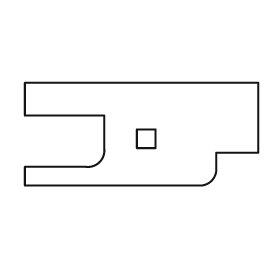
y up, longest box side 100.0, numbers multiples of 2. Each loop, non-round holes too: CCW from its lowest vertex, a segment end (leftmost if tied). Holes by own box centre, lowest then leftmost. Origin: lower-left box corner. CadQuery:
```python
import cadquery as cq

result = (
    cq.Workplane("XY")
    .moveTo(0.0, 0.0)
    .lineTo(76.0, 0.0)
    .threePointArc((80.0, 2.0), (82.0, 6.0))
    .lineTo(82.0, 14.0)
    .lineTo(100.0, 14.0)
    .lineTo(100.0, 44.0)
    .lineTo(0.0, 44.0)
    .lineTo(0.0, 30.0)
    .lineTo(34.0, 30.0)
    .lineTo(34.0, 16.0)
    .threePointArc((32.0, 10.0), (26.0, 8.0))
    .lineTo(0.0, 8.0)
    .close()
    .moveTo(48.0, 16.0)
    .lineTo(56.0, 16.0)
    .lineTo(56.0, 24.0)
    .lineTo(48.0, 24.0)
    .close()
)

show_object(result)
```